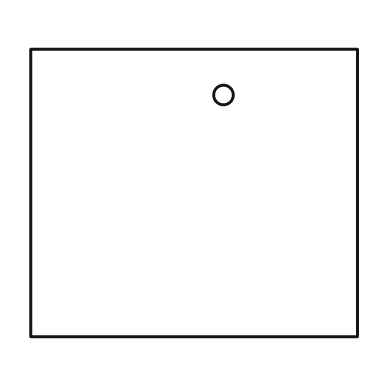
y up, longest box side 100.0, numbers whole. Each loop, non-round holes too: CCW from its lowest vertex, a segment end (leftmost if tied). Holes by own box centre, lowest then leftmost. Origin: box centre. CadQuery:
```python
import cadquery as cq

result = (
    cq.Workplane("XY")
    .moveTo(-50.0, -44.0)
    .lineTo(50.0, -44.0)
    .lineTo(50.0, 44.0)
    .lineTo(-50.0, 44.0)
    .close()
    .moveTo(9.0, 30.0)
    .circle(3.0)
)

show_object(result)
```